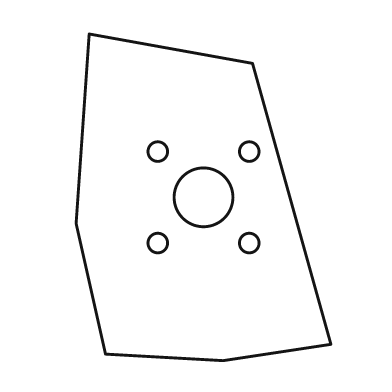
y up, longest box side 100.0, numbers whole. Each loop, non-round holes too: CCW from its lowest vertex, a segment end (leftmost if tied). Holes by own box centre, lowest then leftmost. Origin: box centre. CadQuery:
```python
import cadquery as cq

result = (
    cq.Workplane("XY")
    .moveTo(6.0, -50.0)
    .lineTo(39.0, -45.0)
    .lineTo(15.0, 41.0)
    .lineTo(-35.0, 50.0)
    .lineTo(-39.0, -8.0)
    .lineTo(-30.0, -48.0)
    .close()
    .moveTo(-14.0, -14.0)
    .circle(3.0)
    .moveTo(14.0, -14.0)
    .circle(3.0)
    .moveTo(0.0, 0.0)
    .circle(9.0)
    .moveTo(-14.0, 14.0)
    .circle(3.0)
    .moveTo(14.0, 14.0)
    .circle(3.0)
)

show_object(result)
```